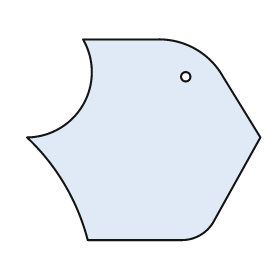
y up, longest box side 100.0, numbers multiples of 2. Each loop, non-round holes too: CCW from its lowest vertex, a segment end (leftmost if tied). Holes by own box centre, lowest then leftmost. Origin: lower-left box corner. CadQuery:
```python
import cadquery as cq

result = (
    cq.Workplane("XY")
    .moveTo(26.0, 0.0)
    .lineTo(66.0, 0.0)
    .threePointArc((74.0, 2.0), (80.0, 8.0))
    .lineTo(100.0, 44.0)
    .lineTo(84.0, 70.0)
    .threePointArc((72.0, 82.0), (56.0, 86.0))
    .lineTo(24.0, 86.0)
    .threePointArc((24.0, 58.0), (0.0, 44.0))
    .threePointArc((16.0, 24.0), (26.0, 0.0))
    .close()
    .moveTo(68.0, 70.0)
    .circle(2.0)
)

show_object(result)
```